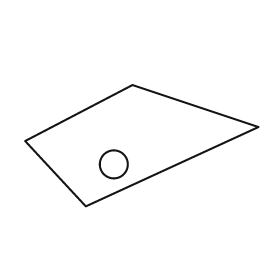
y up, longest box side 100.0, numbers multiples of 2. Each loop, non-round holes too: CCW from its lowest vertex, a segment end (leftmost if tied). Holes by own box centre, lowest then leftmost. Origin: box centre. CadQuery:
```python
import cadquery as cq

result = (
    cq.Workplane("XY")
    .moveTo(-24.0, -26.0)
    .lineTo(50.0, 8.0)
    .lineTo(-4.0, 26.0)
    .lineTo(-50.0, 2.0)
    .close()
    .moveTo(-12.0, -8.0)
    .circle(6.0)
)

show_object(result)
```